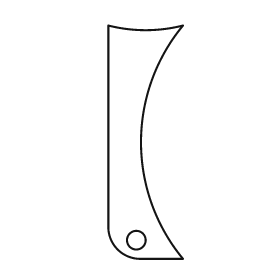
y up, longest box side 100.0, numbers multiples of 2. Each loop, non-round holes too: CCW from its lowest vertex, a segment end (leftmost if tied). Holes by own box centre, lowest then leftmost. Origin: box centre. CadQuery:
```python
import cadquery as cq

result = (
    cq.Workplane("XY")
    .moveTo(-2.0, -50.0)
    .lineTo(16.0, -50.0)
    .threePointArc((-2.0, 0.0), (16.0, 50.0))
    .threePointArc((0.0, 48.0), (-16.0, 50.0))
    .lineTo(-16.0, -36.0)
    .threePointArc((-12.0, -46.0), (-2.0, -50.0))
    .close()
    .moveTo(-4.0, -42.0)
    .circle(4.0)
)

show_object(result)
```